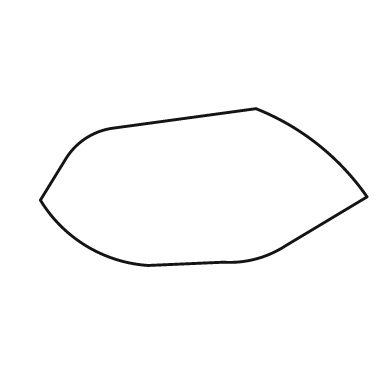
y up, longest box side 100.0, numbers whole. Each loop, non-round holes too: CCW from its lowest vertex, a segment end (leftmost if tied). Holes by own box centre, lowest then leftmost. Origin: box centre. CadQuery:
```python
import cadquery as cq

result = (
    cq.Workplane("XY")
    .moveTo(-17.0, -24.0)
    .lineTo(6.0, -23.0)
    .threePointArc((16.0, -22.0), (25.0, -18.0))
    .lineTo(50.0, -3.0)
    .threePointArc((35.0, 13.0), (16.0, 24.0))
    .lineTo(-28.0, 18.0)
    .threePointArc((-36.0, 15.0), (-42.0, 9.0))
    .lineTo(-50.0, -4.0)
    .threePointArc((-36.0, -18.0), (-17.0, -24.0))
    .close()
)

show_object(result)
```